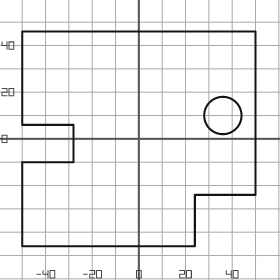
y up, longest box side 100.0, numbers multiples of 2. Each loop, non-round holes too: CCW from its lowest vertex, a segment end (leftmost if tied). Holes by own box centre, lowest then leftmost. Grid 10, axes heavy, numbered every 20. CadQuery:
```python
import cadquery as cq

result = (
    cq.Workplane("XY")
    .moveTo(-50.0, -46.0)
    .lineTo(24.0, -46.0)
    .lineTo(24.0, -24.0)
    .lineTo(50.0, -24.0)
    .lineTo(50.0, 46.0)
    .lineTo(-50.0, 46.0)
    .lineTo(-50.0, 6.0)
    .lineTo(-28.0, 6.0)
    .lineTo(-28.0, -10.0)
    .lineTo(-50.0, -10.0)
    .close()
    .moveTo(36.0, 10.0)
    .circle(8.0)
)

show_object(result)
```